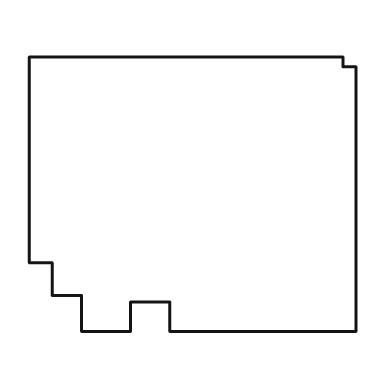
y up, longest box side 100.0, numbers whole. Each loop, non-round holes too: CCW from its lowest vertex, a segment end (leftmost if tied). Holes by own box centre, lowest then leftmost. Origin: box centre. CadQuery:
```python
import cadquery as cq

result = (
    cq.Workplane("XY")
    .moveTo(-34.0, -42.0)
    .lineTo(-19.0, -42.0)
    .lineTo(-19.0, -33.0)
    .lineTo(-7.0, -33.0)
    .lineTo(-7.0, -42.0)
    .lineTo(50.0, -42.0)
    .lineTo(50.0, 39.0)
    .lineTo(46.0, 39.0)
    .lineTo(46.0, 42.0)
    .lineTo(-50.0, 42.0)
    .lineTo(-50.0, -21.0)
    .lineTo(-43.0, -21.0)
    .lineTo(-43.0, -31.0)
    .lineTo(-34.0, -31.0)
    .close()
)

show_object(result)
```